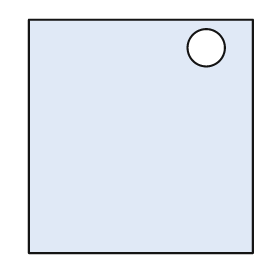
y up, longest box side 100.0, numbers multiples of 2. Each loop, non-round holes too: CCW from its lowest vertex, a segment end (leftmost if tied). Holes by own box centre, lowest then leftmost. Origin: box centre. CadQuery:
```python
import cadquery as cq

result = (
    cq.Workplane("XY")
    .moveTo(-48.0, -50.0)
    .lineTo(48.0, -50.0)
    .lineTo(48.0, 50.0)
    .lineTo(-48.0, 50.0)
    .close()
    .moveTo(28.0, 38.0)
    .circle(8.0)
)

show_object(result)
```